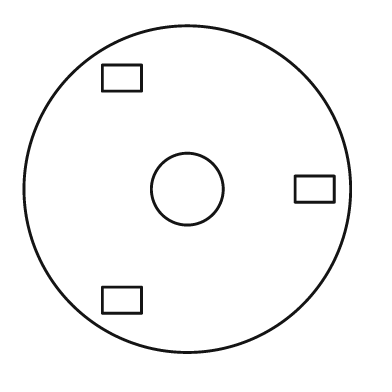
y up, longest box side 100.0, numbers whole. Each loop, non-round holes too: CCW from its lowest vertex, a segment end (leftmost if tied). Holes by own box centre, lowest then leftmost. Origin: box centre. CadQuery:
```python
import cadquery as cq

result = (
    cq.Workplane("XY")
    .moveTo(0.0, 0.0)
    .circle(50.0)
    .moveTo(-26.0, -38.0)
    .lineTo(-14.0, -38.0)
    .lineTo(-14.0, -30.0)
    .lineTo(-26.0, -30.0)
    .close()
    .moveTo(0.0, 0.0)
    .circle(11.0)
    .moveTo(33.0, -4.0)
    .lineTo(45.0, -4.0)
    .lineTo(45.0, 4.0)
    .lineTo(33.0, 4.0)
    .close()
    .moveTo(-26.0, 30.0)
    .lineTo(-14.0, 30.0)
    .lineTo(-14.0, 38.0)
    .lineTo(-26.0, 38.0)
    .close()
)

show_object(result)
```